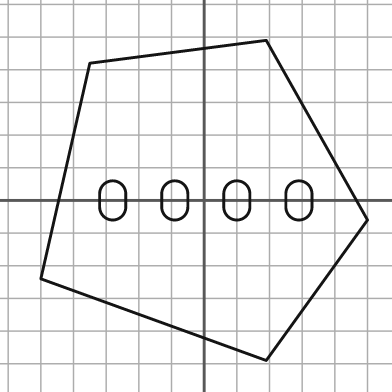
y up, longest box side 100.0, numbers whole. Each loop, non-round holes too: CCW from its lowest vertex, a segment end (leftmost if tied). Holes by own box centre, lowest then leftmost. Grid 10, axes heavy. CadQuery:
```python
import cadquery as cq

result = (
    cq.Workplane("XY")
    .moveTo(19.0, -49.0)
    .lineTo(50.0, -6.0)
    .lineTo(19.0, 49.0)
    .lineTo(-35.0, 42.0)
    .lineTo(-50.0, -24.0)
    .close()
    .moveTo(-32.0, -2.0)
    .threePointArc((-28.0, -6.0), (-24.0, -2.0))
    .lineTo(-24.0, 2.0)
    .threePointArc((-28.0, 6.0), (-32.0, 2.0))
    .close()
    .moveTo(-13.0, -2.0)
    .threePointArc((-9.0, -6.0), (-5.0, -2.0))
    .lineTo(-5.0, 2.0)
    .threePointArc((-9.0, 6.0), (-13.0, 2.0))
    .close()
    .moveTo(6.0, -2.0)
    .threePointArc((10.0, -6.0), (14.0, -2.0))
    .lineTo(14.0, 2.0)
    .threePointArc((10.0, 6.0), (6.0, 2.0))
    .close()
    .moveTo(25.0, -2.0)
    .threePointArc((29.0, -6.0), (33.0, -2.0))
    .lineTo(33.0, 2.0)
    .threePointArc((29.0, 6.0), (25.0, 2.0))
    .close()
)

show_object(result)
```